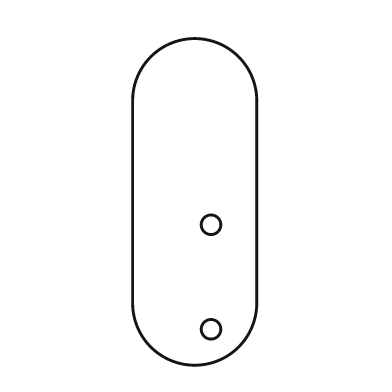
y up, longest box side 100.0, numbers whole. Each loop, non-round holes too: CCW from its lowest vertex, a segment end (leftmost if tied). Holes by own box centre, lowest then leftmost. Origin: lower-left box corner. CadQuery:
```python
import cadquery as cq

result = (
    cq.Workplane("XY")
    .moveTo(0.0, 19.0)
    .threePointArc((19.0, 0.0), (38.0, 19.0))
    .lineTo(38.0, 81.0)
    .threePointArc((19.0, 100.0), (0.0, 81.0))
    .close()
    .moveTo(24.0, 11.0)
    .circle(3.0)
    .moveTo(24.0, 43.0)
    .circle(3.0)
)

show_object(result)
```